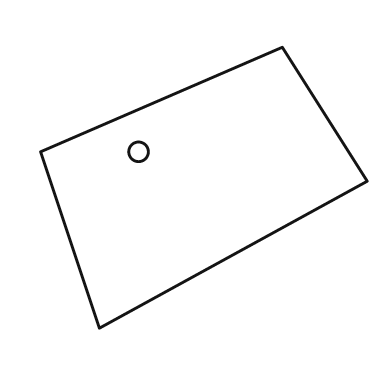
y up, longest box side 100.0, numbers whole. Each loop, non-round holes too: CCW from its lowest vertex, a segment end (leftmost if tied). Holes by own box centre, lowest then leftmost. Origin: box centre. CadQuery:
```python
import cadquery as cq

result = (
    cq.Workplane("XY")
    .moveTo(-32.0, -43.0)
    .lineTo(50.0, 2.0)
    .lineTo(24.0, 43.0)
    .lineTo(-50.0, 11.0)
    .close()
    .moveTo(-20.0, 11.0)
    .circle(3.0)
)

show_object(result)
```